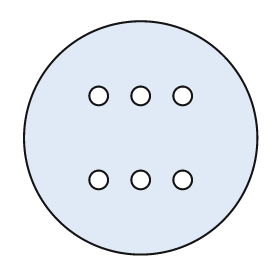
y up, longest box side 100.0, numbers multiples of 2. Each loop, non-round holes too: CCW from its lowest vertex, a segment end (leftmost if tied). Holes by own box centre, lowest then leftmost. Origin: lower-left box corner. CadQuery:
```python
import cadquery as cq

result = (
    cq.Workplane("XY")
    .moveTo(50.0, 50.0)
    .circle(50.0)
    .moveTo(32.0, 32.0)
    .circle(4.0)
    .moveTo(50.0, 32.0)
    .circle(4.0)
    .moveTo(68.0, 32.0)
    .circle(4.0)
    .moveTo(32.0, 68.0)
    .circle(4.0)
    .moveTo(50.0, 68.0)
    .circle(4.0)
    .moveTo(68.0, 68.0)
    .circle(4.0)
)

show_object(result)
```